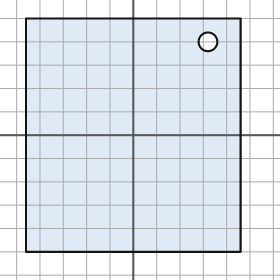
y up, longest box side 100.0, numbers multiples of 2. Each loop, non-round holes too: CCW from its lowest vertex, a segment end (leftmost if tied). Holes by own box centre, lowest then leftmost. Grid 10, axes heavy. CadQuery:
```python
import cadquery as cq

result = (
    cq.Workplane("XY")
    .moveTo(-46.0, -50.0)
    .lineTo(46.0, -50.0)
    .lineTo(46.0, 50.0)
    .lineTo(-46.0, 50.0)
    .close()
    .moveTo(32.0, 40.0)
    .circle(4.0)
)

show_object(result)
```